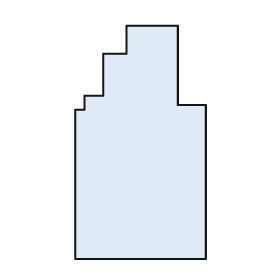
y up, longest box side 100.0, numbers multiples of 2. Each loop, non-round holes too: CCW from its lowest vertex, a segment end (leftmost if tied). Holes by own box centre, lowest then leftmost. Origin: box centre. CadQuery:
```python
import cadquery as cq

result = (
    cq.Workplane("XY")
    .moveTo(-28.0, -50.0)
    .lineTo(28.0, -50.0)
    .lineTo(28.0, 16.0)
    .lineTo(16.0, 16.0)
    .lineTo(16.0, 50.0)
    .lineTo(-6.0, 50.0)
    .lineTo(-6.0, 38.0)
    .lineTo(-16.0, 38.0)
    .lineTo(-16.0, 20.0)
    .lineTo(-24.0, 20.0)
    .lineTo(-24.0, 14.0)
    .lineTo(-28.0, 14.0)
    .close()
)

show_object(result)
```